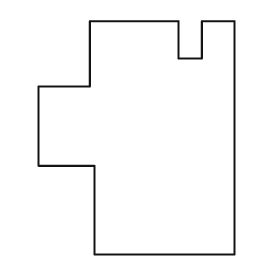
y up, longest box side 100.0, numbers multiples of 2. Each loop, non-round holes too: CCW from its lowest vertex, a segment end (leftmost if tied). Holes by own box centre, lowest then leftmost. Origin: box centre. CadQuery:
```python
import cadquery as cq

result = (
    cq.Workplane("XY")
    .moveTo(-18.0, -50.0)
    .lineTo(42.0, -50.0)
    .lineTo(42.0, 50.0)
    .lineTo(28.0, 50.0)
    .lineTo(28.0, 34.0)
    .lineTo(18.0, 34.0)
    .lineTo(18.0, 50.0)
    .lineTo(-20.0, 50.0)
    .lineTo(-20.0, 22.0)
    .lineTo(-42.0, 22.0)
    .lineTo(-42.0, -12.0)
    .lineTo(-18.0, -12.0)
    .close()
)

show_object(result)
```